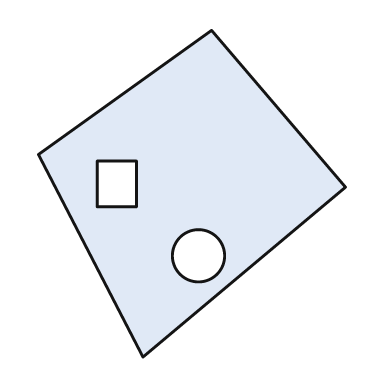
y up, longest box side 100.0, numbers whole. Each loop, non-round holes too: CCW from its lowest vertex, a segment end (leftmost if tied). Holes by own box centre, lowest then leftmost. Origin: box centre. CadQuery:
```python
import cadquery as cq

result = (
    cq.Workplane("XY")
    .moveTo(-15.0, -50.0)
    .lineTo(47.0, 2.0)
    .lineTo(6.0, 50.0)
    .lineTo(-47.0, 12.0)
    .close()
    .moveTo(2.0, -19.0)
    .circle(8.0)
    .moveTo(-29.0, -4.0)
    .lineTo(-17.0, -4.0)
    .lineTo(-17.0, 10.0)
    .lineTo(-29.0, 10.0)
    .close()
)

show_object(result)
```